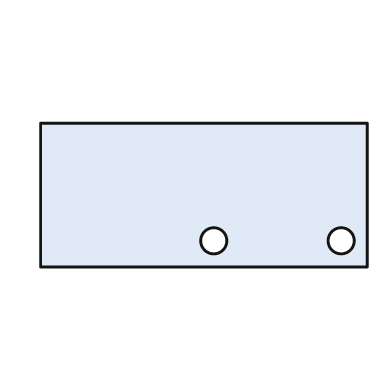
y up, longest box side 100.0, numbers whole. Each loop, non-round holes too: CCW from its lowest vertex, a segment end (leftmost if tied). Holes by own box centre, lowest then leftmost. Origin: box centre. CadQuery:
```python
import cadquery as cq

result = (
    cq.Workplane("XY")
    .moveTo(-50.0, -22.0)
    .lineTo(50.0, -22.0)
    .lineTo(50.0, 22.0)
    .lineTo(-50.0, 22.0)
    .close()
    .moveTo(3.0, -14.0)
    .circle(4.0)
    .moveTo(42.0, -14.0)
    .circle(4.0)
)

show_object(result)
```